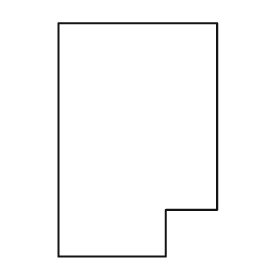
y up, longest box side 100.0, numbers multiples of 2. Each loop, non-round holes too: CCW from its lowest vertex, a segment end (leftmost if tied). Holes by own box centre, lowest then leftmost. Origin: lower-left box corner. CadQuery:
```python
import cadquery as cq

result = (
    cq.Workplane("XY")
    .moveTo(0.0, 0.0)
    .lineTo(46.0, 0.0)
    .lineTo(46.0, 20.0)
    .lineTo(68.0, 20.0)
    .lineTo(68.0, 100.0)
    .lineTo(0.0, 100.0)
    .close()
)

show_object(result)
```